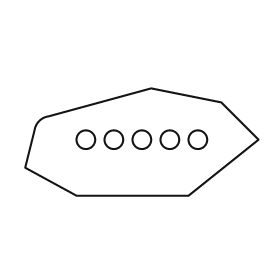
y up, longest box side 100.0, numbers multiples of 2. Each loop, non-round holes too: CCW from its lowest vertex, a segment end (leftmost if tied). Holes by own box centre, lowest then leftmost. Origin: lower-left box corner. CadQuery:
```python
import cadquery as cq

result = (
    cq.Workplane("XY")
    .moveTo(22.0, 0.0)
    .lineTo(70.0, 0.0)
    .lineTo(100.0, 24.0)
    .lineTo(84.0, 40.0)
    .lineTo(54.0, 46.0)
    .lineTo(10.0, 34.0)
    .threePointArc((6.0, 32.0), (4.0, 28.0))
    .lineTo(0.0, 12.0)
    .close()
    .moveTo(26.0, 24.0)
    .circle(4.0)
    .moveTo(38.0, 24.0)
    .circle(4.0)
    .moveTo(50.0, 24.0)
    .circle(4.0)
    .moveTo(62.0, 24.0)
    .circle(4.0)
    .moveTo(74.0, 24.0)
    .circle(4.0)
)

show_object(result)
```